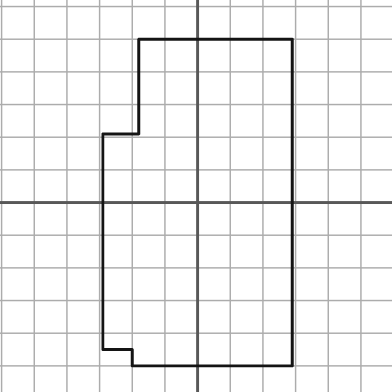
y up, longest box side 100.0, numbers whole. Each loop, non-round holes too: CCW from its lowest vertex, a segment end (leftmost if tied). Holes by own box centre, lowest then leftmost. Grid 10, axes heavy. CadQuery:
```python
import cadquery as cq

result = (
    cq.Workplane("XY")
    .moveTo(-20.0, -50.0)
    .lineTo(29.0, -50.0)
    .lineTo(29.0, 50.0)
    .lineTo(-18.0, 50.0)
    .lineTo(-18.0, 21.0)
    .lineTo(-29.0, 21.0)
    .lineTo(-29.0, -45.0)
    .lineTo(-20.0, -45.0)
    .close()
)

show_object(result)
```